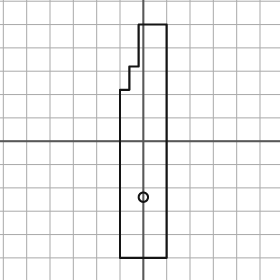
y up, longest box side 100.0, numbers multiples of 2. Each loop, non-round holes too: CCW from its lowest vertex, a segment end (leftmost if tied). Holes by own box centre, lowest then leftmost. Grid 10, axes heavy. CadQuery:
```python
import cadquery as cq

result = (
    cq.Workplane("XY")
    .moveTo(-10.0, -50.0)
    .lineTo(10.0, -50.0)
    .lineTo(10.0, 50.0)
    .lineTo(-2.0, 50.0)
    .lineTo(-2.0, 32.0)
    .lineTo(-6.0, 32.0)
    .lineTo(-6.0, 22.0)
    .lineTo(-10.0, 22.0)
    .close()
    .moveTo(0.0, -24.0)
    .circle(2.0)
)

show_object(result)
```